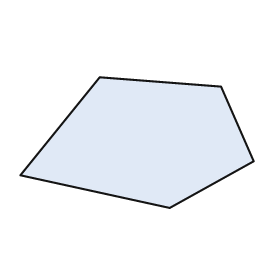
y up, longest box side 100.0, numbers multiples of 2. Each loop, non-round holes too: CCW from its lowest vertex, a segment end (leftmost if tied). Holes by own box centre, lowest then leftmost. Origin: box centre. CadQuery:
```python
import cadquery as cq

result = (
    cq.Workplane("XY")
    .moveTo(14.0, -28.0)
    .lineTo(50.0, -8.0)
    .lineTo(36.0, 24.0)
    .lineTo(-16.0, 28.0)
    .lineTo(-50.0, -14.0)
    .close()
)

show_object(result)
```